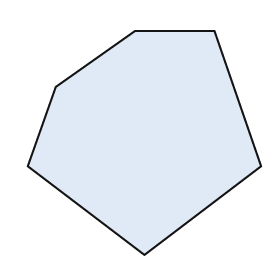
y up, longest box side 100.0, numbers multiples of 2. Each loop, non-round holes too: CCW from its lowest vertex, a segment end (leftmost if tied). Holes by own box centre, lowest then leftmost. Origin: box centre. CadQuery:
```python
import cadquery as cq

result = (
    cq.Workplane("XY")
    .moveTo(0.0, -48.0)
    .lineTo(50.0, -10.0)
    .lineTo(30.0, 48.0)
    .lineTo(-4.0, 48.0)
    .lineTo(-38.0, 24.0)
    .lineTo(-50.0, -10.0)
    .close()
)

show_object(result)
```